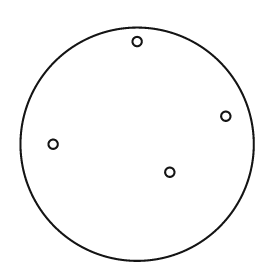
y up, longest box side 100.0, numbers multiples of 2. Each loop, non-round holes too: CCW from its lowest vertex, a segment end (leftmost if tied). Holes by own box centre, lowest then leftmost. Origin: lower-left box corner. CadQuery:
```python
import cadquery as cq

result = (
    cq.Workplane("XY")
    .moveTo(50.0, 50.0)
    .circle(50.0)
    .moveTo(64.0, 38.0)
    .circle(2.0)
    .moveTo(14.0, 50.0)
    .circle(2.0)
    .moveTo(88.0, 62.0)
    .circle(2.0)
    .moveTo(50.0, 94.0)
    .circle(2.0)
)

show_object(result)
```